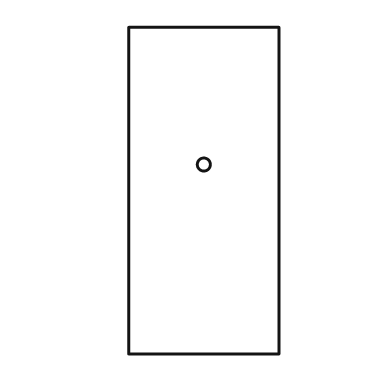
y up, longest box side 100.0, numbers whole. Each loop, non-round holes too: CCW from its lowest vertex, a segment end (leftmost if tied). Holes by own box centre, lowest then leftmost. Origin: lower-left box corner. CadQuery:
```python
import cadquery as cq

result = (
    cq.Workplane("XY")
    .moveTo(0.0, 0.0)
    .lineTo(46.0, 0.0)
    .lineTo(46.0, 100.0)
    .lineTo(0.0, 100.0)
    .close()
    .moveTo(23.0, 58.0)
    .circle(2.0)
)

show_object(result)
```